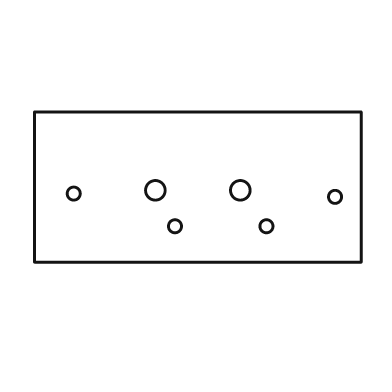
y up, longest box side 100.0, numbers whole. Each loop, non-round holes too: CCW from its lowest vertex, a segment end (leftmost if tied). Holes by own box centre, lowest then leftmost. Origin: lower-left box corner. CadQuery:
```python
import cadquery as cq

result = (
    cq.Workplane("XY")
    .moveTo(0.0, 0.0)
    .lineTo(100.0, 0.0)
    .lineTo(100.0, 46.0)
    .lineTo(0.0, 46.0)
    .close()
    .moveTo(43.0, 11.0)
    .circle(2.0)
    .moveTo(71.0, 11.0)
    .circle(2.0)
    .moveTo(92.0, 20.0)
    .circle(2.0)
    .moveTo(12.0, 21.0)
    .circle(2.0)
    .moveTo(37.0, 22.0)
    .circle(3.0)
    .moveTo(63.0, 22.0)
    .circle(3.0)
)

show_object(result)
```